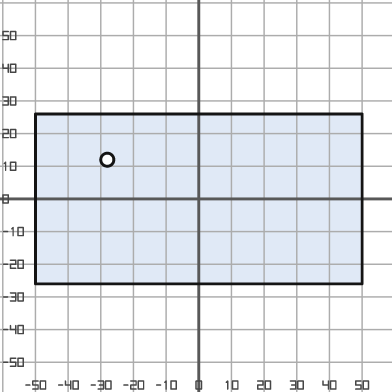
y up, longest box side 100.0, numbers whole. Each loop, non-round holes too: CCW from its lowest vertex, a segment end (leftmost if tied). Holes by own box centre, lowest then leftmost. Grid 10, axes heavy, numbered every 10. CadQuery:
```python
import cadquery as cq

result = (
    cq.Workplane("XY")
    .moveTo(-50.0, -26.0)
    .lineTo(50.0, -26.0)
    .lineTo(50.0, 26.0)
    .lineTo(-50.0, 26.0)
    .close()
    .moveTo(-28.0, 12.0)
    .circle(2.0)
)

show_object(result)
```